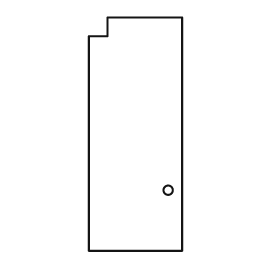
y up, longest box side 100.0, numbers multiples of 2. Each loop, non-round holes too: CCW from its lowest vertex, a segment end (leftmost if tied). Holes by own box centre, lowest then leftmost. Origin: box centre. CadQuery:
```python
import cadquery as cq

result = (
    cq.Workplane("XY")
    .moveTo(-20.0, -50.0)
    .lineTo(20.0, -50.0)
    .lineTo(20.0, 50.0)
    .lineTo(-12.0, 50.0)
    .lineTo(-12.0, 42.0)
    .lineTo(-20.0, 42.0)
    .close()
    .moveTo(14.0, -24.0)
    .circle(2.0)
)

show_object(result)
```